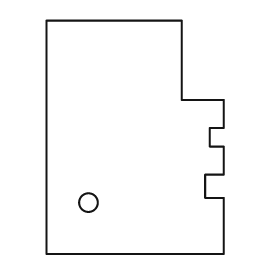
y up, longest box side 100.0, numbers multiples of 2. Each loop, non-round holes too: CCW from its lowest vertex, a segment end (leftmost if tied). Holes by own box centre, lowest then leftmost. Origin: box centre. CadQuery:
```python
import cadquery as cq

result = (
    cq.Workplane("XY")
    .moveTo(-38.0, -50.0)
    .lineTo(38.0, -50.0)
    .lineTo(38.0, -26.0)
    .lineTo(30.0, -26.0)
    .lineTo(30.0, -16.0)
    .lineTo(38.0, -16.0)
    .lineTo(38.0, -4.0)
    .lineTo(32.0, -4.0)
    .lineTo(32.0, 4.0)
    .lineTo(38.0, 4.0)
    .lineTo(38.0, 16.0)
    .lineTo(20.0, 16.0)
    .lineTo(20.0, 50.0)
    .lineTo(-38.0, 50.0)
    .close()
    .moveTo(-20.0, -28.0)
    .circle(4.0)
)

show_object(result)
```